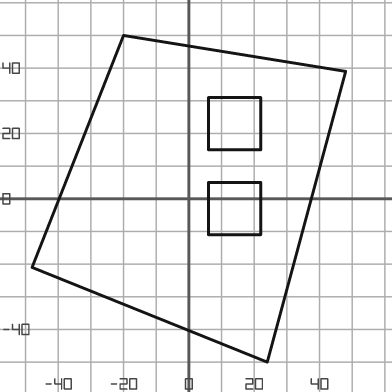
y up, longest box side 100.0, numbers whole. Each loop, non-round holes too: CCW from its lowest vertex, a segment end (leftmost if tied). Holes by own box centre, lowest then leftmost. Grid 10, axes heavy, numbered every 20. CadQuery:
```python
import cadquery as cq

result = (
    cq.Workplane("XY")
    .moveTo(24.0, -50.0)
    .lineTo(48.0, 39.0)
    .lineTo(-20.0, 50.0)
    .lineTo(-48.0, -21.0)
    .close()
    .moveTo(6.0, -11.0)
    .lineTo(22.0, -11.0)
    .lineTo(22.0, 5.0)
    .lineTo(6.0, 5.0)
    .close()
    .moveTo(6.0, 15.0)
    .lineTo(22.0, 15.0)
    .lineTo(22.0, 31.0)
    .lineTo(6.0, 31.0)
    .close()
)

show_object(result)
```